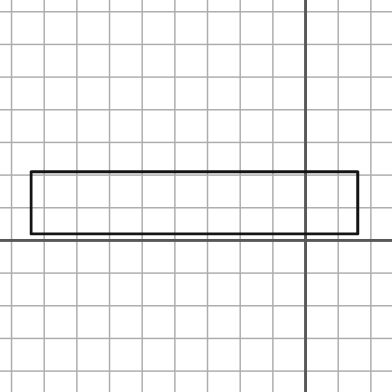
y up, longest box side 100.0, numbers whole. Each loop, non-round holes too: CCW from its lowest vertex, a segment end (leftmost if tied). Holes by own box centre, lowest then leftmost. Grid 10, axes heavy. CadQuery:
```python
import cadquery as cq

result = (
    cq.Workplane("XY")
    .moveTo(-84.0, 2.0)
    .lineTo(16.0, 2.0)
    .lineTo(16.0, 21.0)
    .lineTo(-84.0, 21.0)
    .close()
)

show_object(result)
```